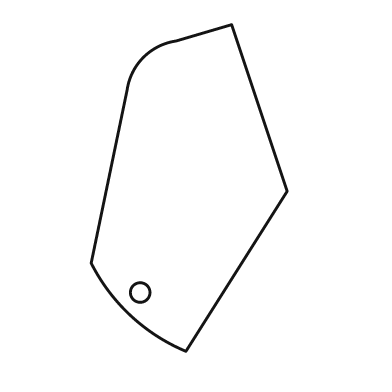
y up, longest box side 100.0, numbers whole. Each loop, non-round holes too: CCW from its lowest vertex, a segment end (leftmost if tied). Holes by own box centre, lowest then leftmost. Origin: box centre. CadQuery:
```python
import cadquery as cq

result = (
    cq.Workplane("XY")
    .moveTo(-1.0, -50.0)
    .lineTo(30.0, -1.0)
    .lineTo(13.0, 50.0)
    .lineTo(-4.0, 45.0)
    .threePointArc((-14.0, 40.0), (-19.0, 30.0))
    .lineTo(-30.0, -23.0)
    .threePointArc((-18.0, -39.0), (-1.0, -50.0))
    .close()
    .moveTo(-15.0, -32.0)
    .circle(3.0)
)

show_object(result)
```